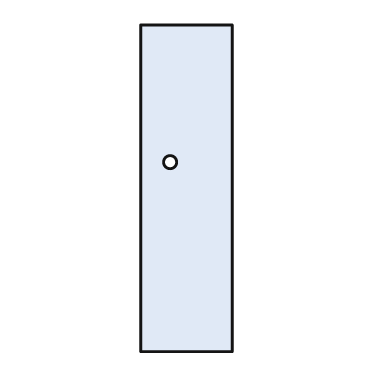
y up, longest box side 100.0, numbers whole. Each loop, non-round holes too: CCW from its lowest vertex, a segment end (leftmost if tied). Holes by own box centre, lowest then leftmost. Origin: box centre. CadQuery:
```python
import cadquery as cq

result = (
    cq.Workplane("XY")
    .moveTo(-14.0, -50.0)
    .lineTo(14.0, -50.0)
    .lineTo(14.0, 50.0)
    .lineTo(-14.0, 50.0)
    .close()
    .moveTo(-5.0, 8.0)
    .circle(2.0)
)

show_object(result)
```